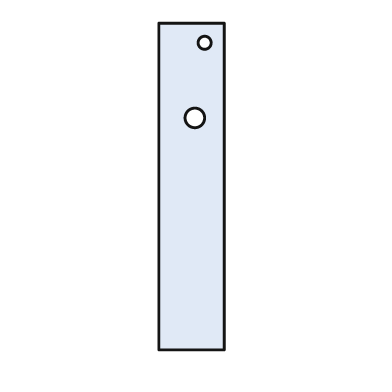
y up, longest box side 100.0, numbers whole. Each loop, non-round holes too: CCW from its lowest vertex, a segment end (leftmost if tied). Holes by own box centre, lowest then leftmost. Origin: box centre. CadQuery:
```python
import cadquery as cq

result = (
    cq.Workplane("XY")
    .moveTo(-10.0, -50.0)
    .lineTo(10.0, -50.0)
    .lineTo(10.0, 50.0)
    .lineTo(-10.0, 50.0)
    .close()
    .moveTo(1.0, 21.0)
    .circle(3.0)
    .moveTo(4.0, 44.0)
    .circle(2.0)
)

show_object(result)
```